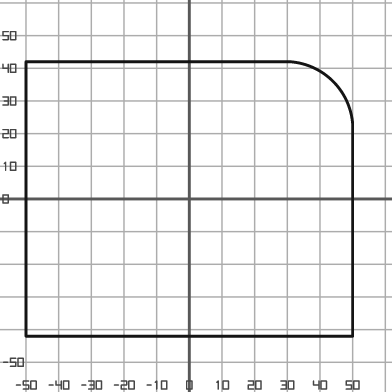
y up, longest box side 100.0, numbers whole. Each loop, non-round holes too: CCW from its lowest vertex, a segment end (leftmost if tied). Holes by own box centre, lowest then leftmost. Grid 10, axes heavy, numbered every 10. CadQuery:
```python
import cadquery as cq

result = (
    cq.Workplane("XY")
    .moveTo(-50.0, -42.0)
    .lineTo(50.0, -42.0)
    .lineTo(50.0, 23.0)
    .threePointArc((44.0, 36.0), (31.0, 42.0))
    .lineTo(-50.0, 42.0)
    .close()
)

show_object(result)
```